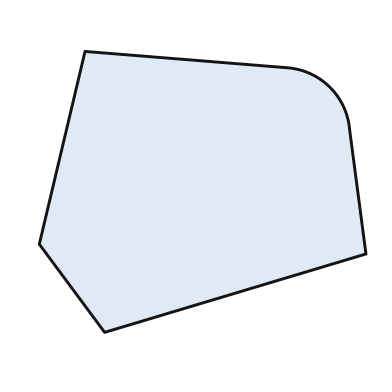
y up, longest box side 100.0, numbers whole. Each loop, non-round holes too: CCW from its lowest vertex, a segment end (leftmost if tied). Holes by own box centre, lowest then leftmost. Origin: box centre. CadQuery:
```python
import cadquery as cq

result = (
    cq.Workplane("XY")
    .moveTo(-30.0, -43.0)
    .lineTo(50.0, -19.0)
    .lineTo(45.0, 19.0)
    .threePointArc((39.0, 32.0), (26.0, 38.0))
    .lineTo(-36.0, 43.0)
    .lineTo(-50.0, -16.0)
    .close()
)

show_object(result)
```